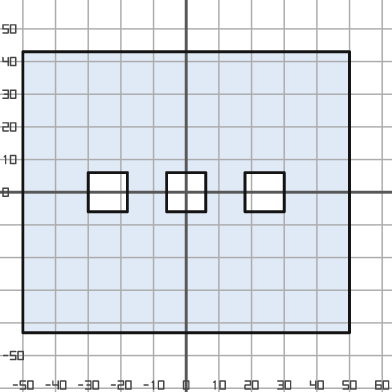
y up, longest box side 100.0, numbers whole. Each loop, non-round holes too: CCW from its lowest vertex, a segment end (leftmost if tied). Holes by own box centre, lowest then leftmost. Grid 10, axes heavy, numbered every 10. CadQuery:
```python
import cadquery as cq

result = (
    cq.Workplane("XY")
    .moveTo(-50.0, -43.0)
    .lineTo(50.0, -43.0)
    .lineTo(50.0, 43.0)
    .lineTo(-50.0, 43.0)
    .close()
    .moveTo(-30.0, -6.0)
    .lineTo(-18.0, -6.0)
    .lineTo(-18.0, 6.0)
    .lineTo(-30.0, 6.0)
    .close()
    .moveTo(-6.0, -6.0)
    .lineTo(6.0, -6.0)
    .lineTo(6.0, 6.0)
    .lineTo(-6.0, 6.0)
    .close()
    .moveTo(18.0, -6.0)
    .lineTo(30.0, -6.0)
    .lineTo(30.0, 6.0)
    .lineTo(18.0, 6.0)
    .close()
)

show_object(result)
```